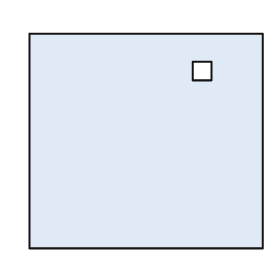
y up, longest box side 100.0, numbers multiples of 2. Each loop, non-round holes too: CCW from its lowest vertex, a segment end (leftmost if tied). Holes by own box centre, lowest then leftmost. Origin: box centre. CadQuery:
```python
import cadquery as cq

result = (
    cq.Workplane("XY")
    .moveTo(-50.0, -46.0)
    .lineTo(50.0, -46.0)
    .lineTo(50.0, 46.0)
    .lineTo(-50.0, 46.0)
    .close()
    .moveTo(20.0, 26.0)
    .lineTo(28.0, 26.0)
    .lineTo(28.0, 34.0)
    .lineTo(20.0, 34.0)
    .close()
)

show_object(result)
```